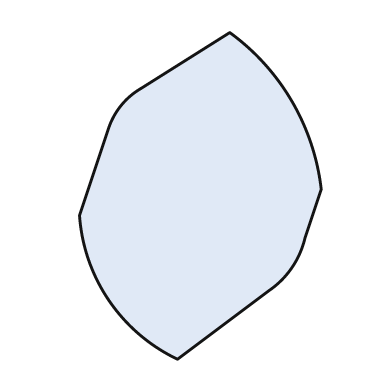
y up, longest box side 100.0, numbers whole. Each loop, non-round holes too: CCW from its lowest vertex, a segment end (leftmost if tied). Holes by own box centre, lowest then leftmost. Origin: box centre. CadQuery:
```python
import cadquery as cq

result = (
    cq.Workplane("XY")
    .moveTo(-7.0, -50.0)
    .lineTo(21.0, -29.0)
    .threePointArc((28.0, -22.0), (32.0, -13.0))
    .lineTo(37.0, 2.0)
    .threePointArc((28.0, 29.0), (9.0, 50.0))
    .lineTo(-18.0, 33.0)
    .threePointArc((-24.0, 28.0), (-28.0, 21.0))
    .lineTo(-37.0, -6.0)
    .threePointArc((-28.0, -32.0), (-7.0, -50.0))
    .close()
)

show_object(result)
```